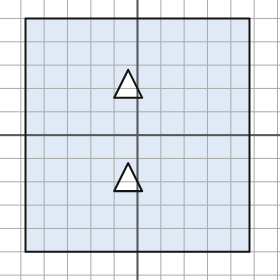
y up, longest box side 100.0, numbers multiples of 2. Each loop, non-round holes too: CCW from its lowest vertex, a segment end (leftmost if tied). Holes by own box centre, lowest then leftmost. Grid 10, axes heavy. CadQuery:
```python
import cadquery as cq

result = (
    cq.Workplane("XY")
    .moveTo(-48.0, -50.0)
    .lineTo(48.0, -50.0)
    .lineTo(48.0, 50.0)
    .lineTo(-48.0, 50.0)
    .close()
    .moveTo(-10.0, -24.0)
    .lineTo(2.0, -24.0)
    .lineTo(-4.0, -12.0)
    .close()
    .moveTo(-10.0, 16.0)
    .lineTo(2.0, 16.0)
    .lineTo(-4.0, 28.0)
    .close()
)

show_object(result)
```